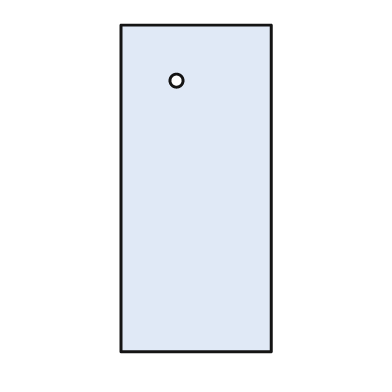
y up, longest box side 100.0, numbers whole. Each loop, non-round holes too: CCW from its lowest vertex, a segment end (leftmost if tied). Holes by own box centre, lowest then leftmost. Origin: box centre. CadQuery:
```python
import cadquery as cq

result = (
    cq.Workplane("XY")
    .moveTo(-23.0, -50.0)
    .lineTo(23.0, -50.0)
    .lineTo(23.0, 50.0)
    .lineTo(-23.0, 50.0)
    .close()
    .moveTo(-6.0, 33.0)
    .circle(2.0)
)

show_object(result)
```